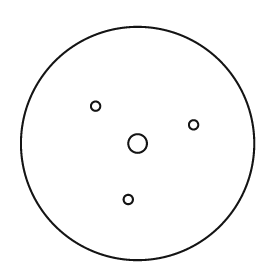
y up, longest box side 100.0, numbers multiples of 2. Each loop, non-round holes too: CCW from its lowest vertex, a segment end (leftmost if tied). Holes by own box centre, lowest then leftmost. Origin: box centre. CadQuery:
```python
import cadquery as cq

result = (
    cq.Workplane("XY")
    .moveTo(0.0, 0.0)
    .circle(50.0)
    .moveTo(-4.0, -24.0)
    .circle(2.0)
    .moveTo(0.0, 0.0)
    .circle(4.0)
    .moveTo(24.0, 8.0)
    .circle(2.0)
    .moveTo(-18.0, 16.0)
    .circle(2.0)
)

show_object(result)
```